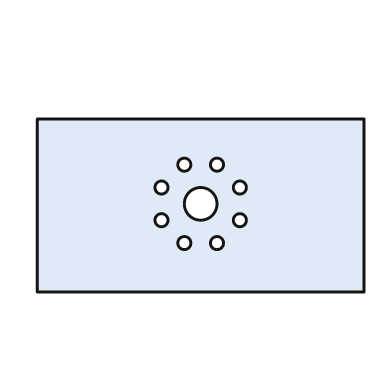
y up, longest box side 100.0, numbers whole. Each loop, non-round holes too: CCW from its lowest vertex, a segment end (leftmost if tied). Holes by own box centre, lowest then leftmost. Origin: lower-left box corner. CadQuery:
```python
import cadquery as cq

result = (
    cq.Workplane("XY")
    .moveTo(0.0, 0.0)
    .lineTo(100.0, 0.0)
    .lineTo(100.0, 53.0)
    .lineTo(0.0, 53.0)
    .close()
    .moveTo(45.0, 15.0)
    .circle(2.0)
    .moveTo(55.0, 15.0)
    .circle(2.0)
    .moveTo(38.0, 22.0)
    .circle(2.0)
    .moveTo(62.0, 22.0)
    .circle(2.0)
    .moveTo(50.0, 27.0)
    .circle(5.0)
    .moveTo(38.0, 32.0)
    .circle(2.0)
    .moveTo(62.0, 32.0)
    .circle(2.0)
    .moveTo(45.0, 39.0)
    .circle(2.0)
    .moveTo(55.0, 39.0)
    .circle(2.0)
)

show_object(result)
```